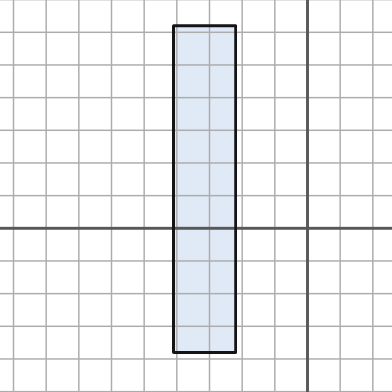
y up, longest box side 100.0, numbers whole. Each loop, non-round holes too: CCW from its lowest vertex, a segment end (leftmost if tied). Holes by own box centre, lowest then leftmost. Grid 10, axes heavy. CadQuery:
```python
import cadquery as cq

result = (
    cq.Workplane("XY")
    .moveTo(-41.0, -38.0)
    .lineTo(-22.0, -38.0)
    .lineTo(-22.0, 62.0)
    .lineTo(-41.0, 62.0)
    .close()
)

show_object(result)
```